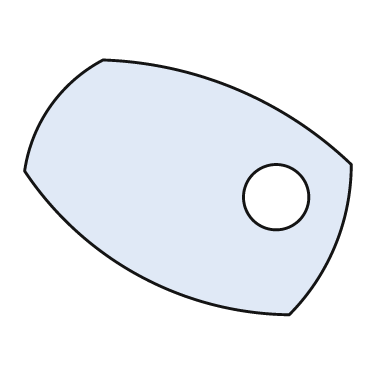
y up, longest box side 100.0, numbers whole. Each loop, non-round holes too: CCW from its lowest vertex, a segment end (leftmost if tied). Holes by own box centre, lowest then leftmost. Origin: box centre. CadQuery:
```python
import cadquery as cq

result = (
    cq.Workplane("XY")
    .moveTo(31.0, -39.0)
    .threePointArc((45.0, -18.0), (50.0, 7.0))
    .threePointArc((15.0, 30.0), (-26.0, 39.0))
    .threePointArc((-42.0, 25.0), (-50.0, 5.0))
    .threePointArc((-15.0, -27.0), (31.0, -39.0))
    .close()
    .moveTo(27.0, -3.0)
    .circle(10.0)
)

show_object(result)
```